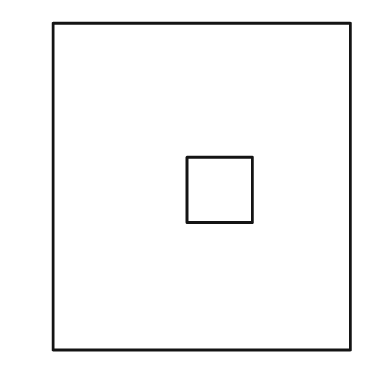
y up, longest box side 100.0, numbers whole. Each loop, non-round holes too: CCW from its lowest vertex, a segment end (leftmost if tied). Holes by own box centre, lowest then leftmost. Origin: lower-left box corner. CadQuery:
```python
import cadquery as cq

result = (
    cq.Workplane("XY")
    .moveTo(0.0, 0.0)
    .lineTo(91.0, 0.0)
    .lineTo(91.0, 100.0)
    .lineTo(0.0, 100.0)
    .close()
    .moveTo(41.0, 39.0)
    .lineTo(61.0, 39.0)
    .lineTo(61.0, 59.0)
    .lineTo(41.0, 59.0)
    .close()
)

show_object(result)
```